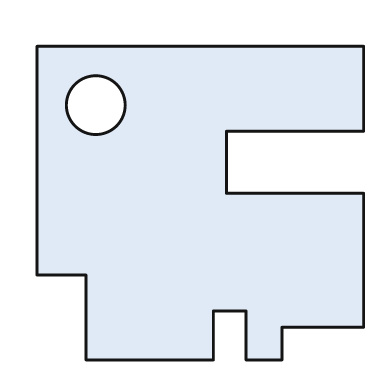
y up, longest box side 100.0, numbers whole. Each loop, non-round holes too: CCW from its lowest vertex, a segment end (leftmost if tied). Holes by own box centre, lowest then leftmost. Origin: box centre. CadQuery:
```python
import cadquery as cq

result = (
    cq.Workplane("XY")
    .moveTo(-35.0, -48.0)
    .lineTo(4.0, -48.0)
    .lineTo(4.0, -33.0)
    .lineTo(14.0, -33.0)
    .lineTo(14.0, -48.0)
    .lineTo(25.0, -48.0)
    .lineTo(25.0, -38.0)
    .lineTo(50.0, -38.0)
    .lineTo(50.0, 3.0)
    .lineTo(8.0, 3.0)
    .lineTo(8.0, 22.0)
    .lineTo(50.0, 22.0)
    .lineTo(50.0, 48.0)
    .lineTo(-50.0, 48.0)
    .lineTo(-50.0, -22.0)
    .lineTo(-35.0, -22.0)
    .close()
    .moveTo(-32.0, 30.0)
    .circle(9.0)
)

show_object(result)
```